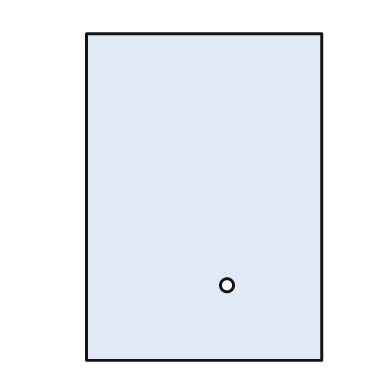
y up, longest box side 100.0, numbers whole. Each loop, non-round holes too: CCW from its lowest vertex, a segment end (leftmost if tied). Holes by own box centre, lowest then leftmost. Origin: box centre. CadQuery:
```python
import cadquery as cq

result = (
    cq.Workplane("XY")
    .moveTo(-36.0, -50.0)
    .lineTo(36.0, -50.0)
    .lineTo(36.0, 50.0)
    .lineTo(-36.0, 50.0)
    .close()
    .moveTo(7.0, -27.0)
    .circle(2.0)
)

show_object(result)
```